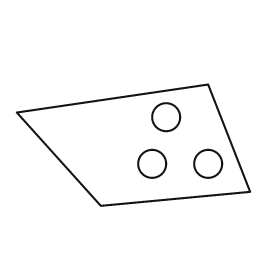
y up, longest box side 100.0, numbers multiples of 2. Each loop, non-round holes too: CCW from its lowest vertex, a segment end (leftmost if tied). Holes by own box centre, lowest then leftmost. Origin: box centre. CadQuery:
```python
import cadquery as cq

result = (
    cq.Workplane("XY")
    .moveTo(-14.0, -26.0)
    .lineTo(50.0, -20.0)
    .lineTo(32.0, 26.0)
    .lineTo(-50.0, 14.0)
    .close()
    .moveTo(8.0, -8.0)
    .circle(6.0)
    .moveTo(32.0, -8.0)
    .circle(6.0)
    .moveTo(14.0, 12.0)
    .circle(6.0)
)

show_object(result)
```